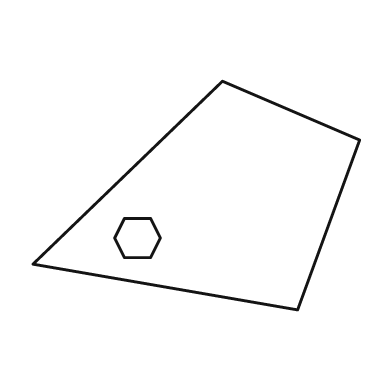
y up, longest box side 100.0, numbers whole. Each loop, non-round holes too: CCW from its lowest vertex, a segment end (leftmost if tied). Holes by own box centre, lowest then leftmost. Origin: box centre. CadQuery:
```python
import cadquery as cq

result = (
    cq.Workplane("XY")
    .moveTo(31.0, -35.0)
    .lineTo(50.0, 17.0)
    .lineTo(8.0, 35.0)
    .lineTo(-50.0, -21.0)
    .close()
    .moveTo(-22.0, -19.0)
    .lineTo(-14.0, -19.0)
    .lineTo(-11.0, -13.0)
    .lineTo(-14.0, -7.0)
    .lineTo(-22.0, -7.0)
    .lineTo(-25.0, -13.0)
    .close()
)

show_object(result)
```